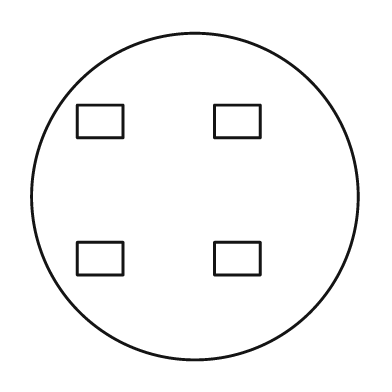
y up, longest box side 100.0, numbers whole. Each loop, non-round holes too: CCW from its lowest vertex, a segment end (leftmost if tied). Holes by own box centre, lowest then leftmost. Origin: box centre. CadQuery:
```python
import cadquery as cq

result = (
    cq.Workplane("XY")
    .moveTo(0.0, 0.0)
    .circle(50.0)
    .moveTo(-36.0, -24.0)
    .lineTo(-22.0, -24.0)
    .lineTo(-22.0, -14.0)
    .lineTo(-36.0, -14.0)
    .close()
    .moveTo(6.0, -24.0)
    .lineTo(20.0, -24.0)
    .lineTo(20.0, -14.0)
    .lineTo(6.0, -14.0)
    .close()
    .moveTo(-36.0, 18.0)
    .lineTo(-22.0, 18.0)
    .lineTo(-22.0, 28.0)
    .lineTo(-36.0, 28.0)
    .close()
    .moveTo(6.0, 18.0)
    .lineTo(20.0, 18.0)
    .lineTo(20.0, 28.0)
    .lineTo(6.0, 28.0)
    .close()
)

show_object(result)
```